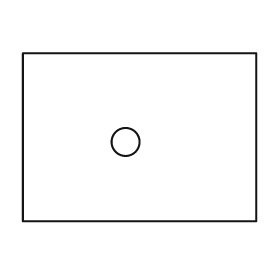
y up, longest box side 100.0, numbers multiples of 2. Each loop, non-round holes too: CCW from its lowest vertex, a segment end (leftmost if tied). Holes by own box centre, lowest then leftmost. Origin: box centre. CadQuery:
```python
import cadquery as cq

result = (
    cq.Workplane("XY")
    .moveTo(-50.0, -36.0)
    .lineTo(50.0, -36.0)
    .lineTo(50.0, 36.0)
    .lineTo(-50.0, 36.0)
    .close()
    .moveTo(-6.0, -2.0)
    .circle(6.0)
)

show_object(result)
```